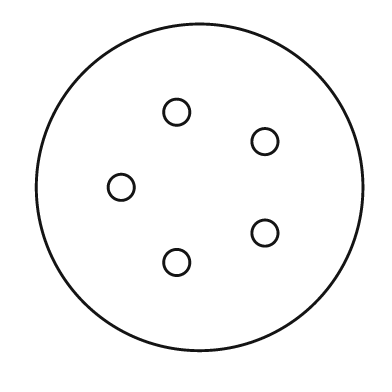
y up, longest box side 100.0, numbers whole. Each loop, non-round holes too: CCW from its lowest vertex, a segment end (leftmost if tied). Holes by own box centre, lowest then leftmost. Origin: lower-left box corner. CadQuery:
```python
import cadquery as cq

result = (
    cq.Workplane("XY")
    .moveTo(50.0, 50.0)
    .circle(50.0)
    .moveTo(43.0, 27.0)
    .circle(4.0)
    .moveTo(70.0, 36.0)
    .circle(4.0)
    .moveTo(26.0, 50.0)
    .circle(4.0)
    .moveTo(70.0, 64.0)
    .circle(4.0)
    .moveTo(43.0, 73.0)
    .circle(4.0)
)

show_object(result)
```